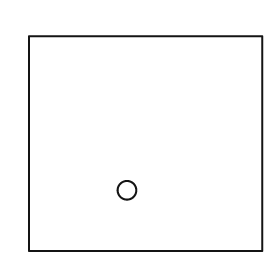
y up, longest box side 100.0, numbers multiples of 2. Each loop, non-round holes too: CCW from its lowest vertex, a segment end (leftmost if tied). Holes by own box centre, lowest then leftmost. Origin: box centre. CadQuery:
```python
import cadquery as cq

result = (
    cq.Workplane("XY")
    .moveTo(-50.0, -46.0)
    .lineTo(50.0, -46.0)
    .lineTo(50.0, 46.0)
    .lineTo(-50.0, 46.0)
    .close()
    .moveTo(-8.0, -20.0)
    .circle(4.0)
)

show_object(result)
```